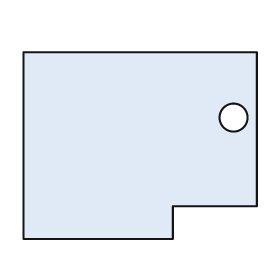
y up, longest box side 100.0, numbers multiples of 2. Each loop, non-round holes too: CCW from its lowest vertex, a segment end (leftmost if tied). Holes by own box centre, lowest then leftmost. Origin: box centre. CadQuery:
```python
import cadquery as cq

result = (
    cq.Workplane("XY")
    .moveTo(-50.0, -40.0)
    .lineTo(14.0, -40.0)
    .lineTo(14.0, -26.0)
    .lineTo(50.0, -26.0)
    .lineTo(50.0, 40.0)
    .lineTo(-50.0, 40.0)
    .close()
    .moveTo(40.0, 12.0)
    .circle(6.0)
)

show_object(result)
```